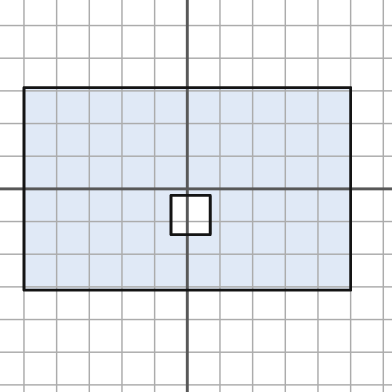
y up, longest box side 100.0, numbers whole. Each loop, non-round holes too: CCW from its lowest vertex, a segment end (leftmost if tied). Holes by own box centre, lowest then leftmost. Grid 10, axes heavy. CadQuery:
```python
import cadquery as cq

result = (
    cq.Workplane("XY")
    .moveTo(-50.0, -31.0)
    .lineTo(50.0, -31.0)
    .lineTo(50.0, 31.0)
    .lineTo(-50.0, 31.0)
    .close()
    .moveTo(-5.0, -14.0)
    .lineTo(7.0, -14.0)
    .lineTo(7.0, -2.0)
    .lineTo(-5.0, -2.0)
    .close()
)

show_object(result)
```